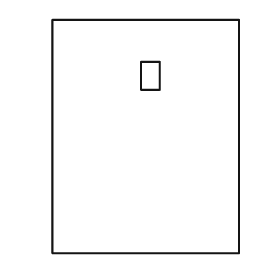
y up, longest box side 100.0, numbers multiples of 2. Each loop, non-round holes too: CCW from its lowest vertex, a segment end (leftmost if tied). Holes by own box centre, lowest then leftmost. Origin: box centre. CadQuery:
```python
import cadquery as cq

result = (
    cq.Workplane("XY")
    .moveTo(-40.0, -50.0)
    .lineTo(40.0, -50.0)
    .lineTo(40.0, 50.0)
    .lineTo(-40.0, 50.0)
    .close()
    .moveTo(-2.0, 20.0)
    .lineTo(6.0, 20.0)
    .lineTo(6.0, 32.0)
    .lineTo(-2.0, 32.0)
    .close()
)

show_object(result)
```